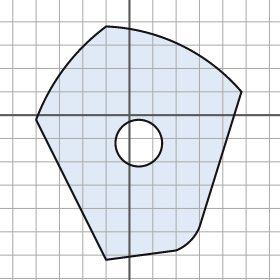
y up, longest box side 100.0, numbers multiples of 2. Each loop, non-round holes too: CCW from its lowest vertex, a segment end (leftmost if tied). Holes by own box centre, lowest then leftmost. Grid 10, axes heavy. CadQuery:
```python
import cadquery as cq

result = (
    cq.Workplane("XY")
    .moveTo(-10.0, -62.0)
    .lineTo(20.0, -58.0)
    .threePointArc((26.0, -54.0), (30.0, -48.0))
    .lineTo(48.0, 10.0)
    .threePointArc((22.0, 30.0), (-10.0, 38.0))
    .threePointArc((-28.0, 20.0), (-40.0, -2.0))
    .close()
    .moveTo(4.0, -12.0)
    .circle(10.0)
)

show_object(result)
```